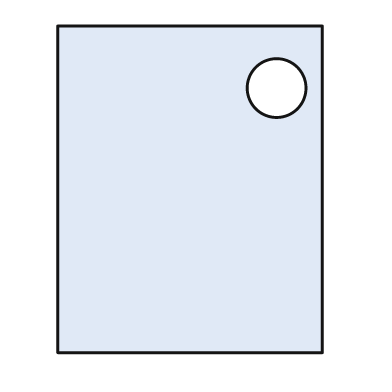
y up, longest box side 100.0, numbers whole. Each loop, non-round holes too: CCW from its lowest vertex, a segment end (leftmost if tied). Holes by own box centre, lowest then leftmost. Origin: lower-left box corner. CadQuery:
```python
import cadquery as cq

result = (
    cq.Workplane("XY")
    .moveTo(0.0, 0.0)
    .lineTo(81.0, 0.0)
    .lineTo(81.0, 100.0)
    .lineTo(0.0, 100.0)
    .close()
    .moveTo(67.0, 81.0)
    .circle(9.0)
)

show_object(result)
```